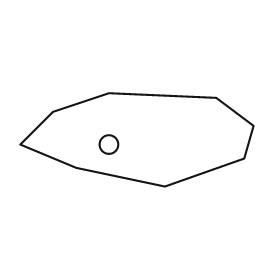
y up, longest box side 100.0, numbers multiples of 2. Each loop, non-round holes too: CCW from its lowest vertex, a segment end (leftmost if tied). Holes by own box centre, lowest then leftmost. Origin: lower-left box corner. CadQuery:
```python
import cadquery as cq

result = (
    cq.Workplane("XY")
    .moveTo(62.0, 0.0)
    .lineTo(96.0, 12.0)
    .lineTo(100.0, 26.0)
    .lineTo(84.0, 38.0)
    .lineTo(38.0, 40.0)
    .lineTo(14.0, 32.0)
    .lineTo(0.0, 18.0)
    .lineTo(24.0, 8.0)
    .close()
    .moveTo(38.0, 18.0)
    .circle(4.0)
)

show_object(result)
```